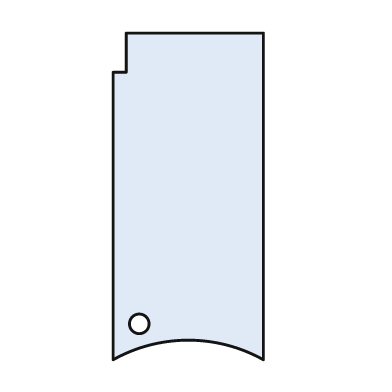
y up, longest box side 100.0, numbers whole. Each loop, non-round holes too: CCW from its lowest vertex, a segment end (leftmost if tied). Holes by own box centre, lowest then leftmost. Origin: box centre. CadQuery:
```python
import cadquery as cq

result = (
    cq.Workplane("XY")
    .moveTo(-23.0, -50.0)
    .threePointArc((0.0, -44.0), (23.0, -50.0))
    .lineTo(23.0, 50.0)
    .lineTo(-19.0, 50.0)
    .lineTo(-19.0, 38.0)
    .lineTo(-23.0, 38.0)
    .close()
    .moveTo(-15.0, -39.0)
    .circle(3.0)
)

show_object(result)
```